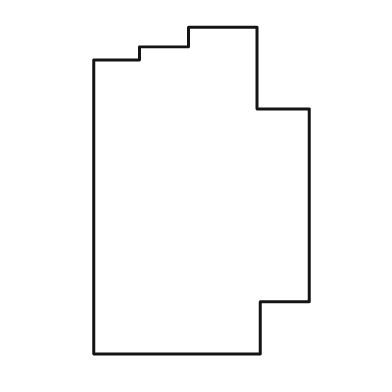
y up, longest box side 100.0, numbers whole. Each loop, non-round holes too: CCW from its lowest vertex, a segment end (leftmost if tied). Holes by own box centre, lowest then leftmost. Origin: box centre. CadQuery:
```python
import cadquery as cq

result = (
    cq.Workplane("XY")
    .moveTo(-33.0, -50.0)
    .lineTo(18.0, -50.0)
    .lineTo(18.0, -34.0)
    .lineTo(33.0, -34.0)
    .lineTo(33.0, 25.0)
    .lineTo(17.0, 25.0)
    .lineTo(17.0, 50.0)
    .lineTo(-4.0, 50.0)
    .lineTo(-4.0, 44.0)
    .lineTo(-19.0, 44.0)
    .lineTo(-19.0, 40.0)
    .lineTo(-33.0, 40.0)
    .close()
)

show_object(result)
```